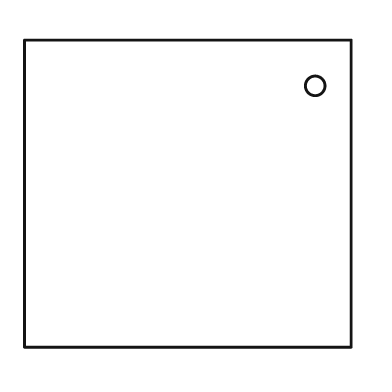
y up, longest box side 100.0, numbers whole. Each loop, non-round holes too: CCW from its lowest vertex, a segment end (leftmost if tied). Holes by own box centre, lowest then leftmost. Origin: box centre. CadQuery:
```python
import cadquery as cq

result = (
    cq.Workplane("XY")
    .moveTo(-50.0, -47.0)
    .lineTo(50.0, -47.0)
    .lineTo(50.0, 47.0)
    .lineTo(-50.0, 47.0)
    .close()
    .moveTo(39.0, 33.0)
    .circle(3.0)
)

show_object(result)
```